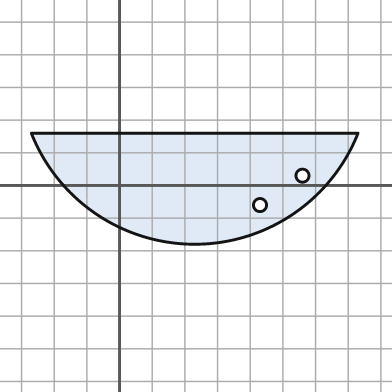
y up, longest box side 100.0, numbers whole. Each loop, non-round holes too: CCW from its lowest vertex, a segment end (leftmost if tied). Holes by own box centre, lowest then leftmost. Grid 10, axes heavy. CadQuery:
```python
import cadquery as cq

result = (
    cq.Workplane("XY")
    .moveTo(-27.0, 16.0)
    .threePointArc((23.0, -18.0), (73.0, 16.0))
    .close()
    .moveTo(43.0, -6.0)
    .circle(2.0)
    .moveTo(56.0, 3.0)
    .circle(2.0)
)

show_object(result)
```